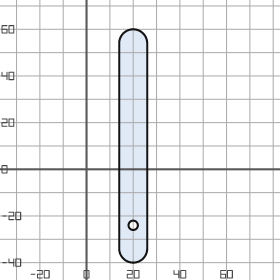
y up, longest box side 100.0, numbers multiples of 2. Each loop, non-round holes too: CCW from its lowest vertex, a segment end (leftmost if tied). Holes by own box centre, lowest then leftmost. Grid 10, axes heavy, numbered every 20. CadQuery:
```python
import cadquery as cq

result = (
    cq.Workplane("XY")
    .moveTo(14.0, -34.0)
    .threePointArc((20.0, -40.0), (26.0, -34.0))
    .lineTo(26.0, 54.0)
    .threePointArc((20.0, 60.0), (14.0, 54.0))
    .close()
    .moveTo(20.0, -24.0)
    .circle(2.0)
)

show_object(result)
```